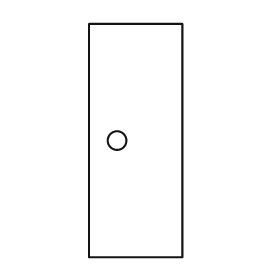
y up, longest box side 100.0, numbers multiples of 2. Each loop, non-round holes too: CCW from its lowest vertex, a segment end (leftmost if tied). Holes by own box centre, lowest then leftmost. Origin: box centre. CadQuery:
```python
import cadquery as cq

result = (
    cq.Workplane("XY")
    .moveTo(-20.0, -50.0)
    .lineTo(20.0, -50.0)
    .lineTo(20.0, 50.0)
    .lineTo(-20.0, 50.0)
    .close()
    .moveTo(-8.0, 0.0)
    .circle(4.0)
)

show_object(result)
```